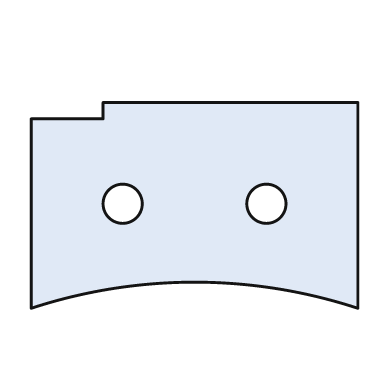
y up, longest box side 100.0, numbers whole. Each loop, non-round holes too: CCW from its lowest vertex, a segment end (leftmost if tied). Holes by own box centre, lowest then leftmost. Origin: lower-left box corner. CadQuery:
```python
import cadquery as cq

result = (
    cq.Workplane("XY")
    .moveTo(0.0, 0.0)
    .threePointArc((50.0, 8.0), (100.0, 0.0))
    .lineTo(100.0, 63.0)
    .lineTo(22.0, 63.0)
    .lineTo(22.0, 58.0)
    .lineTo(0.0, 58.0)
    .close()
    .moveTo(28.0, 32.0)
    .circle(6.0)
    .moveTo(72.0, 32.0)
    .circle(6.0)
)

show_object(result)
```